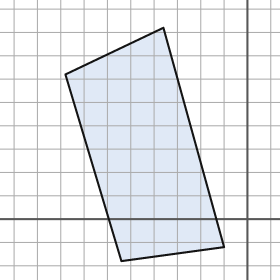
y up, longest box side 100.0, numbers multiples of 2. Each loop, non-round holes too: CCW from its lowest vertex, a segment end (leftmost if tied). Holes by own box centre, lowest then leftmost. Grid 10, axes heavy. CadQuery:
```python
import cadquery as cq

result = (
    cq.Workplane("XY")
    .moveTo(-54.0, -18.0)
    .lineTo(-10.0, -12.0)
    .lineTo(-36.0, 82.0)
    .lineTo(-78.0, 62.0)
    .close()
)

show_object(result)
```